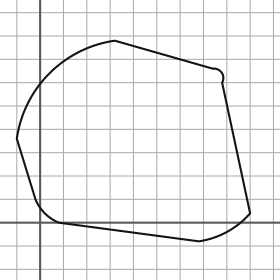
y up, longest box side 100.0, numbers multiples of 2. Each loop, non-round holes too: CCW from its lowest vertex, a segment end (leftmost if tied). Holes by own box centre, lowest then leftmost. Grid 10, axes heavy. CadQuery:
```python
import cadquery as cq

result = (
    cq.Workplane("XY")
    .moveTo(68.0, -8.0)
    .threePointArc((80.0, -4.0), (90.0, 4.0))
    .lineTo(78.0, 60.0)
    .threePointArc((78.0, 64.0), (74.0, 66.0))
    .lineTo(32.0, 78.0)
    .threePointArc((4.0, 64.0), (-10.0, 36.0))
    .lineTo(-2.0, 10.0)
    .threePointArc((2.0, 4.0), (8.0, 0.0))
    .close()
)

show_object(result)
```